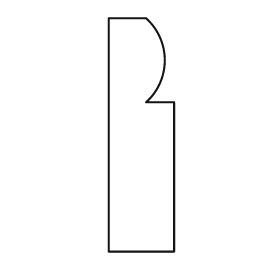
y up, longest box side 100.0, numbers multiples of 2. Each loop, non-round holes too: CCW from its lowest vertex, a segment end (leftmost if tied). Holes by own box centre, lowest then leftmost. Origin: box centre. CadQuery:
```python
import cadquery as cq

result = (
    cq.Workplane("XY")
    .moveTo(-14.0, -50.0)
    .lineTo(14.0, -50.0)
    .lineTo(14.0, 14.0)
    .lineTo(2.0, 14.0)
    .threePointArc((10.0, 32.0), (2.0, 50.0))
    .lineTo(-14.0, 50.0)
    .close()
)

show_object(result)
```